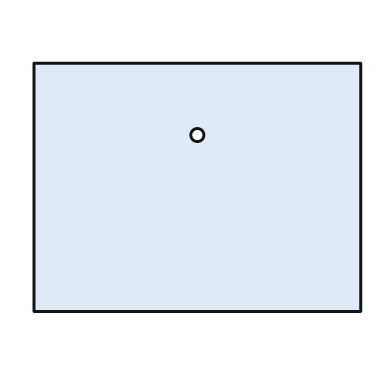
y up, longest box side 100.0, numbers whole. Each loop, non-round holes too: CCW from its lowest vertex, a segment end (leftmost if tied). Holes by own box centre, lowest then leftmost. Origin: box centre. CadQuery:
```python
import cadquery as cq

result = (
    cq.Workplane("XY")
    .moveTo(-50.0, -38.0)
    .lineTo(50.0, -38.0)
    .lineTo(50.0, 38.0)
    .lineTo(-50.0, 38.0)
    .close()
    .moveTo(0.0, 16.0)
    .circle(2.0)
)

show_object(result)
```